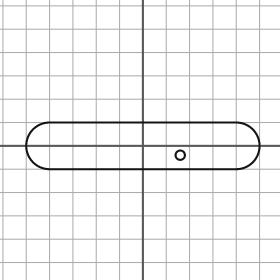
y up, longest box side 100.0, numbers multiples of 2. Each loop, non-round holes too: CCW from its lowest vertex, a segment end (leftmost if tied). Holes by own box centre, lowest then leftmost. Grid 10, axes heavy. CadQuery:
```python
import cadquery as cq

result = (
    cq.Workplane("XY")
    .moveTo(-40.0, -10.0)
    .lineTo(40.0, -10.0)
    .threePointArc((50.0, 0.0), (40.0, 10.0))
    .lineTo(-40.0, 10.0)
    .threePointArc((-50.0, 0.0), (-40.0, -10.0))
    .close()
    .moveTo(16.0, -4.0)
    .circle(2.0)
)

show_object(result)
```